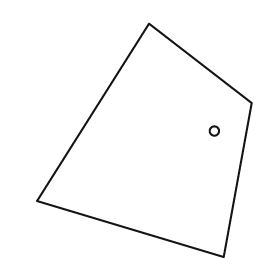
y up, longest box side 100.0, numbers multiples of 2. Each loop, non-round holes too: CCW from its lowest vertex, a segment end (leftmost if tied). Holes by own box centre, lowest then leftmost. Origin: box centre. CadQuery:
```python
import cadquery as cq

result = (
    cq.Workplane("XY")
    .moveTo(34.0, -50.0)
    .lineTo(46.0, 16.0)
    .lineTo(2.0, 50.0)
    .lineTo(-46.0, -26.0)
    .close()
    .moveTo(30.0, 4.0)
    .circle(2.0)
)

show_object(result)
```